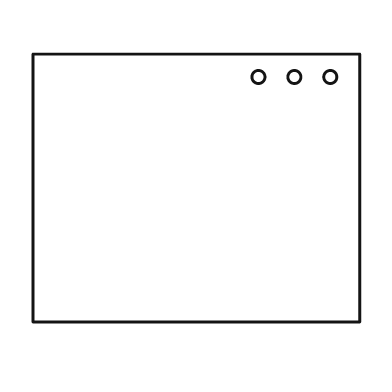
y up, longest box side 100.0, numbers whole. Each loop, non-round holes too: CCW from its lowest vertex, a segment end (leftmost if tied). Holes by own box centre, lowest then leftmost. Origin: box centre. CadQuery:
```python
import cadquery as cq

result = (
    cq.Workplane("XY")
    .moveTo(-50.0, -41.0)
    .lineTo(50.0, -41.0)
    .lineTo(50.0, 41.0)
    .lineTo(-50.0, 41.0)
    .close()
    .moveTo(19.0, 34.0)
    .circle(2.0)
    .moveTo(30.0, 34.0)
    .circle(2.0)
    .moveTo(41.0, 34.0)
    .circle(2.0)
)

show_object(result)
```